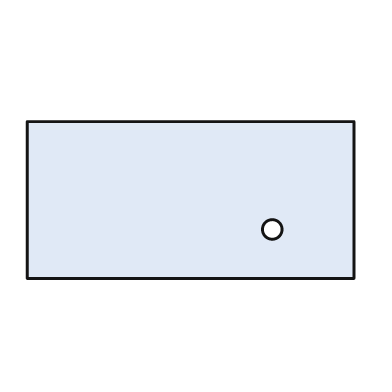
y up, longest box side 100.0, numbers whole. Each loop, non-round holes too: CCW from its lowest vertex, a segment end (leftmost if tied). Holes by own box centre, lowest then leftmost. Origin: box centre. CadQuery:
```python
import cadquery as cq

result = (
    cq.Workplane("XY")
    .moveTo(-50.0, -24.0)
    .lineTo(50.0, -24.0)
    .lineTo(50.0, 24.0)
    .lineTo(-50.0, 24.0)
    .close()
    .moveTo(25.0, -9.0)
    .circle(3.0)
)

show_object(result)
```